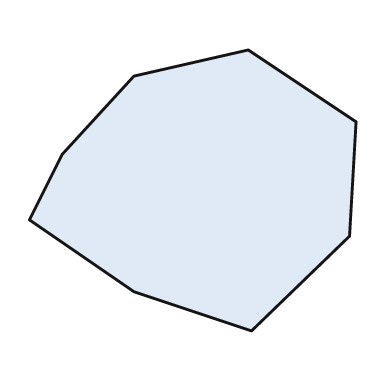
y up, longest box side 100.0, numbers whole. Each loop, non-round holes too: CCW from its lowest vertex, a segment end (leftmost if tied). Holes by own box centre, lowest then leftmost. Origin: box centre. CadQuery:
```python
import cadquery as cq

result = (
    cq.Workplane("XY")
    .moveTo(18.0, -43.0)
    .lineTo(48.0, -14.0)
    .lineTo(50.0, 21.0)
    .lineTo(17.0, 43.0)
    .lineTo(-18.0, 35.0)
    .lineTo(-40.0, 11.0)
    .lineTo(-50.0, -9.0)
    .lineTo(-18.0, -31.0)
    .close()
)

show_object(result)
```